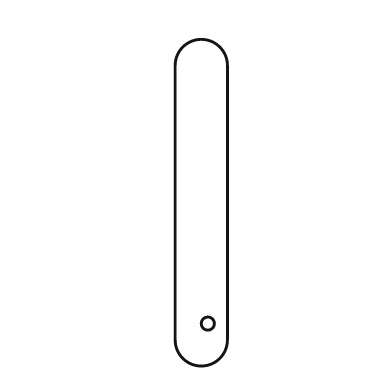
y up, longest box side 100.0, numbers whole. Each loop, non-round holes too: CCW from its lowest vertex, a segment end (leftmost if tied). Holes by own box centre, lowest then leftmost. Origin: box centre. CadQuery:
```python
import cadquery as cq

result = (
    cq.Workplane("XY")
    .moveTo(-8.0, -42.0)
    .threePointArc((0.0, -50.0), (8.0, -42.0))
    .lineTo(8.0, 42.0)
    .threePointArc((0.0, 50.0), (-8.0, 42.0))
    .close()
    .moveTo(2.0, -37.0)
    .circle(2.0)
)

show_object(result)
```